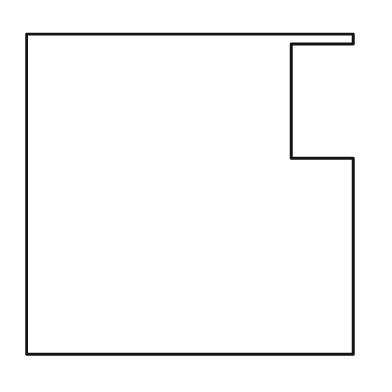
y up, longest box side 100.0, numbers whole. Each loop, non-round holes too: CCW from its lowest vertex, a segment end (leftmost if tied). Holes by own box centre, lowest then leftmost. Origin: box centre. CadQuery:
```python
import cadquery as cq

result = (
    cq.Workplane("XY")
    .moveTo(-50.0, -49.0)
    .lineTo(50.0, -49.0)
    .lineTo(50.0, 11.0)
    .lineTo(31.0, 11.0)
    .lineTo(31.0, 46.0)
    .lineTo(50.0, 46.0)
    .lineTo(50.0, 49.0)
    .lineTo(-50.0, 49.0)
    .close()
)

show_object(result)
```